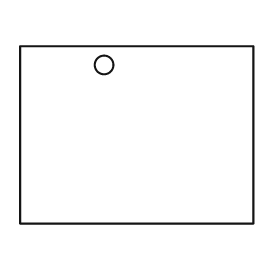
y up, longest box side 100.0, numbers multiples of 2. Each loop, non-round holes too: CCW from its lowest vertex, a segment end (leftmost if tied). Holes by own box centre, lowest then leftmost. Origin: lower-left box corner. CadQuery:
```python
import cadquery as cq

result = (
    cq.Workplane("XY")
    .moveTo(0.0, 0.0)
    .lineTo(100.0, 0.0)
    .lineTo(100.0, 76.0)
    .lineTo(0.0, 76.0)
    .close()
    .moveTo(36.0, 68.0)
    .circle(4.0)
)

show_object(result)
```